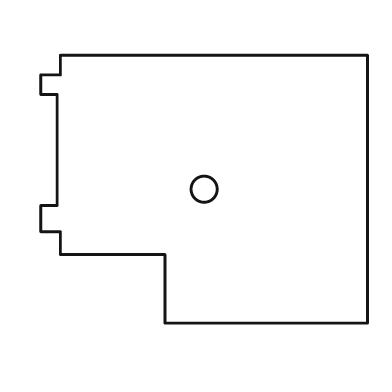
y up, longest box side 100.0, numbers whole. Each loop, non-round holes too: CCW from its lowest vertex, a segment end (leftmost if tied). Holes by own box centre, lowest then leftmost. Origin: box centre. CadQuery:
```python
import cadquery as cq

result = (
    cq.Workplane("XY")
    .moveTo(-12.0, -41.0)
    .lineTo(50.0, -41.0)
    .lineTo(50.0, 41.0)
    .lineTo(-44.0, 41.0)
    .lineTo(-44.0, 35.0)
    .lineTo(-50.0, 35.0)
    .lineTo(-50.0, 29.0)
    .lineTo(-45.0, 29.0)
    .lineTo(-45.0, -5.0)
    .lineTo(-50.0, -5.0)
    .lineTo(-50.0, -13.0)
    .lineTo(-44.0, -13.0)
    .lineTo(-44.0, -20.0)
    .lineTo(-12.0, -20.0)
    .close()
    .moveTo(0.0, 0.0)
    .circle(4.0)
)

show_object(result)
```